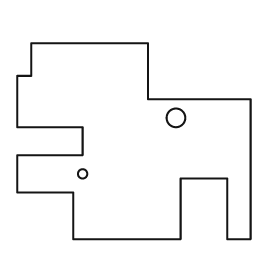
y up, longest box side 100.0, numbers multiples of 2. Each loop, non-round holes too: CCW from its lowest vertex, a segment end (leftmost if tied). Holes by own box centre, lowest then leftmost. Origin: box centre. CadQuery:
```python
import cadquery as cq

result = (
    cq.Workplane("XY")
    .moveTo(-26.0, -42.0)
    .lineTo(20.0, -42.0)
    .lineTo(20.0, -16.0)
    .lineTo(40.0, -16.0)
    .lineTo(40.0, -42.0)
    .lineTo(50.0, -42.0)
    .lineTo(50.0, 18.0)
    .lineTo(6.0, 18.0)
    .lineTo(6.0, 42.0)
    .lineTo(-44.0, 42.0)
    .lineTo(-44.0, 28.0)
    .lineTo(-50.0, 28.0)
    .lineTo(-50.0, 6.0)
    .lineTo(-22.0, 6.0)
    .lineTo(-22.0, -6.0)
    .lineTo(-50.0, -6.0)
    .lineTo(-50.0, -22.0)
    .lineTo(-26.0, -22.0)
    .close()
    .moveTo(-22.0, -14.0)
    .circle(2.0)
    .moveTo(18.0, 10.0)
    .circle(4.0)
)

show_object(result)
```